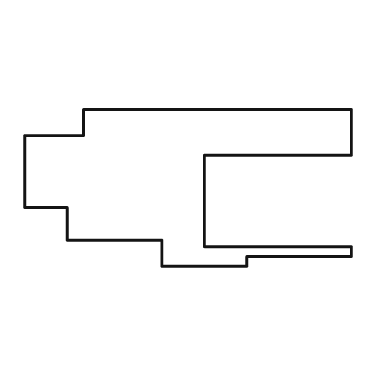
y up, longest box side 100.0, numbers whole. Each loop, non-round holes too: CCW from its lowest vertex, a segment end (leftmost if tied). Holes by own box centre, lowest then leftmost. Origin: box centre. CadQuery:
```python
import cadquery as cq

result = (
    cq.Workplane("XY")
    .moveTo(-8.0, -24.0)
    .lineTo(18.0, -24.0)
    .lineTo(18.0, -21.0)
    .lineTo(50.0, -21.0)
    .lineTo(50.0, -18.0)
    .lineTo(5.0, -18.0)
    .lineTo(5.0, 10.0)
    .lineTo(50.0, 10.0)
    .lineTo(50.0, 24.0)
    .lineTo(-32.0, 24.0)
    .lineTo(-32.0, 16.0)
    .lineTo(-50.0, 16.0)
    .lineTo(-50.0, -6.0)
    .lineTo(-37.0, -6.0)
    .lineTo(-37.0, -16.0)
    .lineTo(-8.0, -16.0)
    .close()
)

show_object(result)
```